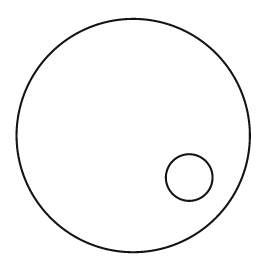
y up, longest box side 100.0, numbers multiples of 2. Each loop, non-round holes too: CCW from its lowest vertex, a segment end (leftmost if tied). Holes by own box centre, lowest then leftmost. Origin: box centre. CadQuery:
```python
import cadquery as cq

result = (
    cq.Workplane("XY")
    .moveTo(0.0, 0.0)
    .circle(50.0)
    .moveTo(24.0, -18.0)
    .circle(10.0)
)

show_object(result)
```